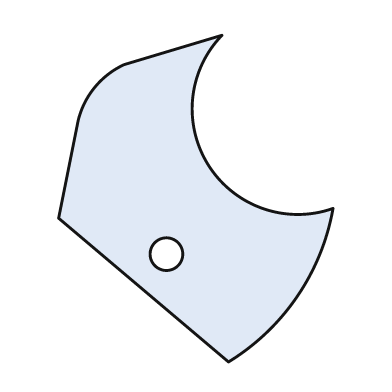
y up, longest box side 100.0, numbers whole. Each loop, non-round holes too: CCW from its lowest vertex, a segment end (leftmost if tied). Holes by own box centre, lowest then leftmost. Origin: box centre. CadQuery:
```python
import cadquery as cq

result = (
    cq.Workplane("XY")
    .moveTo(10.0, -50.0)
    .threePointArc((31.0, -30.0), (42.0, -3.0))
    .threePointArc((4.0, 10.0), (8.0, 50.0))
    .lineTo(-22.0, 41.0)
    .threePointArc((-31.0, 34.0), (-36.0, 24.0))
    .lineTo(-42.0, -6.0)
    .close()
    .moveTo(-9.0, -17.0)
    .circle(5.0)
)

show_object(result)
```